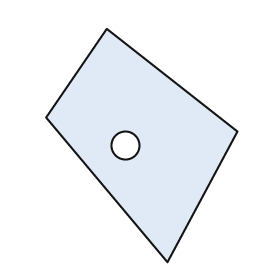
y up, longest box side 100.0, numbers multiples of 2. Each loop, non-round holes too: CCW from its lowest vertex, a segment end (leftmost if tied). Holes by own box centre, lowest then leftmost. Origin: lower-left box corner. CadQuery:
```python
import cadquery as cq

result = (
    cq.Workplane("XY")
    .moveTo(52.0, 0.0)
    .lineTo(82.0, 56.0)
    .lineTo(26.0, 100.0)
    .lineTo(0.0, 62.0)
    .close()
    .moveTo(34.0, 50.0)
    .circle(6.0)
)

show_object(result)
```